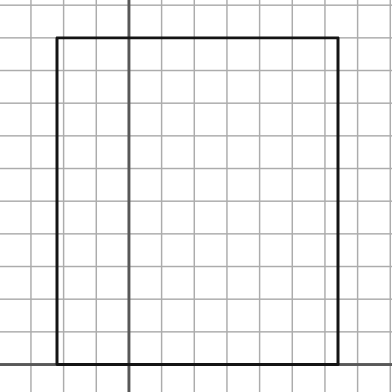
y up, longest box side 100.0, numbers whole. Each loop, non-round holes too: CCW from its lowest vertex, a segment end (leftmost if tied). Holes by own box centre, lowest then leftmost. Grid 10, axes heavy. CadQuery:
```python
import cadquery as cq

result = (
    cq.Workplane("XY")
    .moveTo(-22.0, 0.0)
    .lineTo(64.0, 0.0)
    .lineTo(64.0, 100.0)
    .lineTo(-22.0, 100.0)
    .close()
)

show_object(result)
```